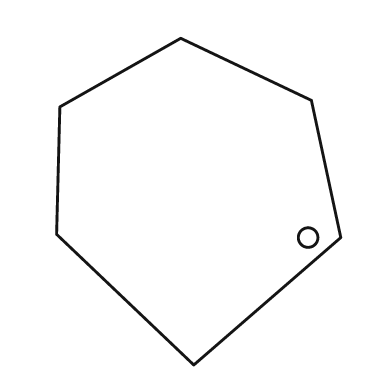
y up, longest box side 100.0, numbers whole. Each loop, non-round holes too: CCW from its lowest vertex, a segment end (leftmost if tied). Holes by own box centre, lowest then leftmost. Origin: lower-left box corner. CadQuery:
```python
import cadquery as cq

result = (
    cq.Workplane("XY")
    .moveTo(42.0, 0.0)
    .lineTo(87.0, 39.0)
    .lineTo(78.0, 81.0)
    .lineTo(38.0, 100.0)
    .lineTo(1.0, 79.0)
    .lineTo(0.0, 40.0)
    .close()
    .moveTo(77.0, 39.0)
    .circle(3.0)
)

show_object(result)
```